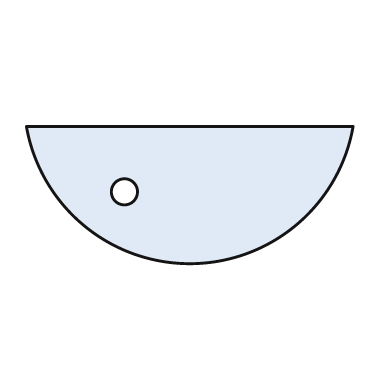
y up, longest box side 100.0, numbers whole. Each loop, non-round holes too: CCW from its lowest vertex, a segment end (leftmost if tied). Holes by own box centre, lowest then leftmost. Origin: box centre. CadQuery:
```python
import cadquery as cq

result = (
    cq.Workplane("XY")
    .moveTo(-50.0, 21.0)
    .threePointArc((0.0, -21.0), (50.0, 21.0))
    .close()
    .moveTo(-20.0, 1.0)
    .circle(4.0)
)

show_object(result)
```